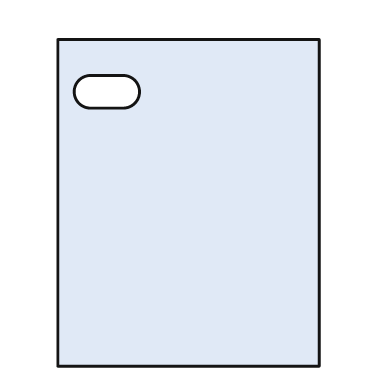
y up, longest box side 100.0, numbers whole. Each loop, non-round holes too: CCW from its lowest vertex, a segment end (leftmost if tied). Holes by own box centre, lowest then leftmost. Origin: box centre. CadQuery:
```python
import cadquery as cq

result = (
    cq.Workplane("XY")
    .moveTo(-40.0, -50.0)
    .lineTo(40.0, -50.0)
    .lineTo(40.0, 50.0)
    .lineTo(-40.0, 50.0)
    .close()
    .moveTo(-30.0, 29.0)
    .lineTo(-20.0, 29.0)
    .threePointArc((-15.0, 34.0), (-20.0, 39.0))
    .lineTo(-30.0, 39.0)
    .threePointArc((-35.0, 34.0), (-30.0, 29.0))
    .close()
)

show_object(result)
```